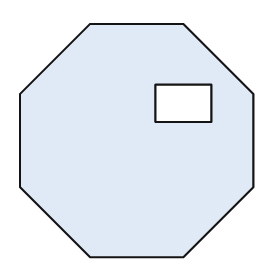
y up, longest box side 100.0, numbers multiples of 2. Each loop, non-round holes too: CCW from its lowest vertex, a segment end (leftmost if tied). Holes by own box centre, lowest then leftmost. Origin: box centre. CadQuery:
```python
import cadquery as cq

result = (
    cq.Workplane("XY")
    .moveTo(-20.0, -50.0)
    .lineTo(20.0, -50.0)
    .lineTo(50.0, -20.0)
    .lineTo(50.0, 20.0)
    .lineTo(20.0, 50.0)
    .lineTo(-20.0, 50.0)
    .lineTo(-50.0, 20.0)
    .lineTo(-50.0, -20.0)
    .close()
    .moveTo(8.0, 8.0)
    .lineTo(32.0, 8.0)
    .lineTo(32.0, 24.0)
    .lineTo(8.0, 24.0)
    .close()
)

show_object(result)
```